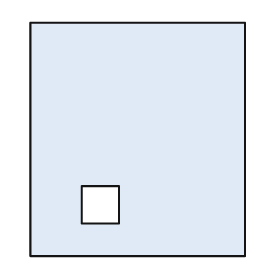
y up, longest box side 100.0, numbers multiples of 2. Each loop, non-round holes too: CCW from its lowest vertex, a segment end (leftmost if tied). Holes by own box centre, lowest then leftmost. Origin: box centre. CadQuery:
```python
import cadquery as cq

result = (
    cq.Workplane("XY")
    .moveTo(-46.0, -50.0)
    .lineTo(46.0, -50.0)
    .lineTo(46.0, 50.0)
    .lineTo(-46.0, 50.0)
    .close()
    .moveTo(-24.0, -36.0)
    .lineTo(-8.0, -36.0)
    .lineTo(-8.0, -20.0)
    .lineTo(-24.0, -20.0)
    .close()
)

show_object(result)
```